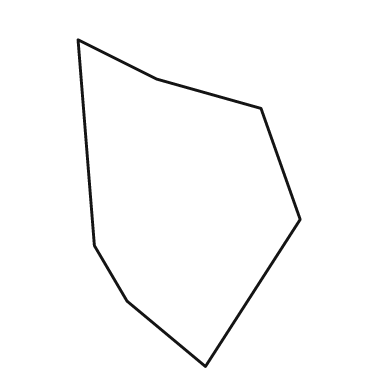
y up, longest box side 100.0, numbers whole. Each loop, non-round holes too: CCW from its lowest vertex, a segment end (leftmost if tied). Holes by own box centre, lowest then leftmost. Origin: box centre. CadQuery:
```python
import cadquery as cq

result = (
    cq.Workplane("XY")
    .moveTo(5.0, -50.0)
    .lineTo(34.0, -5.0)
    .lineTo(22.0, 29.0)
    .lineTo(-10.0, 38.0)
    .lineTo(-34.0, 50.0)
    .lineTo(-29.0, -13.0)
    .lineTo(-19.0, -30.0)
    .close()
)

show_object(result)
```